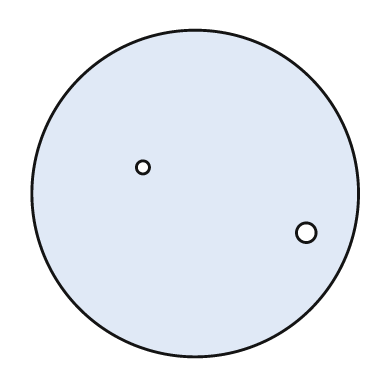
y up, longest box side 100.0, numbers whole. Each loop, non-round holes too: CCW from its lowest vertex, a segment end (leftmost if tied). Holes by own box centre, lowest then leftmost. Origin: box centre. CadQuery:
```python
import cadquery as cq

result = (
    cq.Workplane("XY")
    .moveTo(0.0, 0.0)
    .circle(50.0)
    .moveTo(34.0, -12.0)
    .circle(3.0)
    .moveTo(-16.0, 8.0)
    .circle(2.0)
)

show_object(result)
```